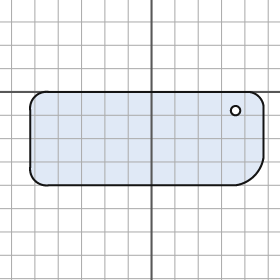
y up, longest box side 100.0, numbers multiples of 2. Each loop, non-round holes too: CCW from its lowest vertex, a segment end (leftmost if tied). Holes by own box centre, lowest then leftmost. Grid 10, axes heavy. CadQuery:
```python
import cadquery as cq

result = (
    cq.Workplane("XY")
    .moveTo(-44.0, -40.0)
    .lineTo(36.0, -40.0)
    .threePointArc((44.0, -36.0), (48.0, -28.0))
    .lineTo(48.0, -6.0)
    .threePointArc((46.0, -2.0), (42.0, 0.0))
    .lineTo(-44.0, 0.0)
    .threePointArc((-50.0, -2.0), (-52.0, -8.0))
    .lineTo(-52.0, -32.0)
    .threePointArc((-50.0, -38.0), (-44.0, -40.0))
    .close()
    .moveTo(36.0, -8.0)
    .circle(2.0)
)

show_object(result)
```